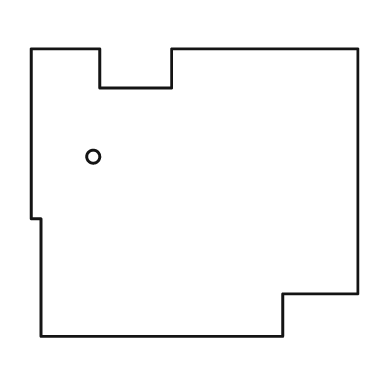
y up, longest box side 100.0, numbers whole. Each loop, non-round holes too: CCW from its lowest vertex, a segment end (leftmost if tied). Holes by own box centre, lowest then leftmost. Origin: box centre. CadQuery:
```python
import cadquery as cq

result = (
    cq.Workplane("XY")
    .moveTo(-47.0, -44.0)
    .lineTo(27.0, -44.0)
    .lineTo(27.0, -31.0)
    .lineTo(50.0, -31.0)
    .lineTo(50.0, 44.0)
    .lineTo(-7.0, 44.0)
    .lineTo(-7.0, 32.0)
    .lineTo(-29.0, 32.0)
    .lineTo(-29.0, 44.0)
    .lineTo(-50.0, 44.0)
    .lineTo(-50.0, -8.0)
    .lineTo(-47.0, -8.0)
    .close()
    .moveTo(-31.0, 11.0)
    .circle(2.0)
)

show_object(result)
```